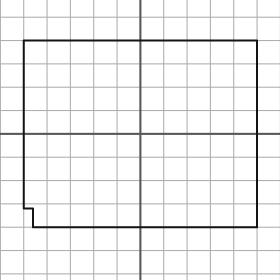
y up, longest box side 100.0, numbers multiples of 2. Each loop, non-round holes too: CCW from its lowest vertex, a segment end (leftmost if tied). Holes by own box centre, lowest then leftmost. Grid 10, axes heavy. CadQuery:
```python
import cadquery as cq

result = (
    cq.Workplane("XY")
    .moveTo(-46.0, -40.0)
    .lineTo(50.0, -40.0)
    .lineTo(50.0, 40.0)
    .lineTo(-50.0, 40.0)
    .lineTo(-50.0, -32.0)
    .lineTo(-46.0, -32.0)
    .close()
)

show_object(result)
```